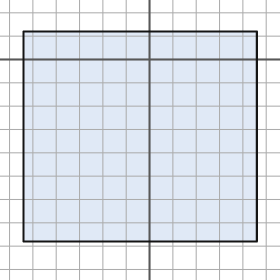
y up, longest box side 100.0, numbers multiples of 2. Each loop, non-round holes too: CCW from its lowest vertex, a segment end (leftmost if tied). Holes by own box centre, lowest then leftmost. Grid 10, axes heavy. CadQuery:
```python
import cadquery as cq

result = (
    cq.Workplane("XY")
    .moveTo(-54.0, -78.0)
    .lineTo(46.0, -78.0)
    .lineTo(46.0, 12.0)
    .lineTo(-54.0, 12.0)
    .close()
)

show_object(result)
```